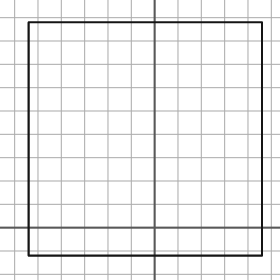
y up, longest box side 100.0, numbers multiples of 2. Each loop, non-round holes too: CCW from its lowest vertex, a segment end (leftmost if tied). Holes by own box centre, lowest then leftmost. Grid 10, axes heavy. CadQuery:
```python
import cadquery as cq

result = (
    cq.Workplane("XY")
    .moveTo(-54.0, -12.0)
    .lineTo(46.0, -12.0)
    .lineTo(46.0, 88.0)
    .lineTo(-54.0, 88.0)
    .close()
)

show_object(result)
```